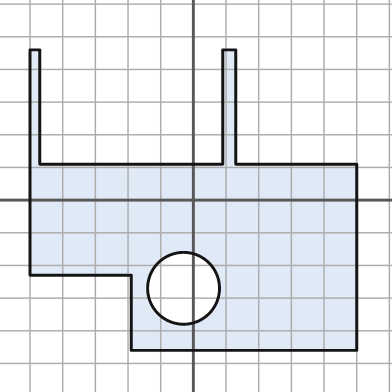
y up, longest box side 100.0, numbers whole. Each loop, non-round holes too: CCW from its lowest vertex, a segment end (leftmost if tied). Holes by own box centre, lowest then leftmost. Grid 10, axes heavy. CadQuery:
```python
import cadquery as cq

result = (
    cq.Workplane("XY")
    .moveTo(-19.0, -46.0)
    .lineTo(50.0, -46.0)
    .lineTo(50.0, 11.0)
    .lineTo(13.0, 11.0)
    .lineTo(13.0, 46.0)
    .lineTo(9.0, 46.0)
    .lineTo(9.0, 11.0)
    .lineTo(-47.0, 11.0)
    .lineTo(-47.0, 46.0)
    .lineTo(-50.0, 46.0)
    .lineTo(-50.0, -23.0)
    .lineTo(-19.0, -23.0)
    .close()
    .moveTo(-3.0, -27.0)
    .circle(11.0)
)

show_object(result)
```